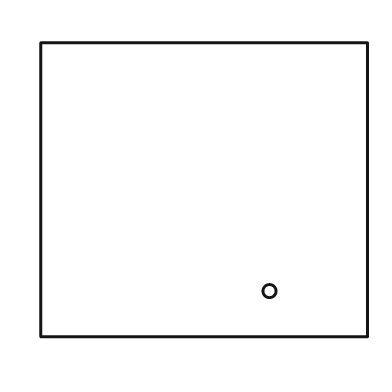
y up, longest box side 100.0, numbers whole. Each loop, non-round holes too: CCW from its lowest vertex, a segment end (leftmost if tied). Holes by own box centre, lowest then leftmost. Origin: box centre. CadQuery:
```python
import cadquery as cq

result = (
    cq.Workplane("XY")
    .moveTo(-50.0, -45.0)
    .lineTo(50.0, -45.0)
    .lineTo(50.0, 45.0)
    .lineTo(-50.0, 45.0)
    .close()
    .moveTo(20.0, -31.0)
    .circle(2.0)
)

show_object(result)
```